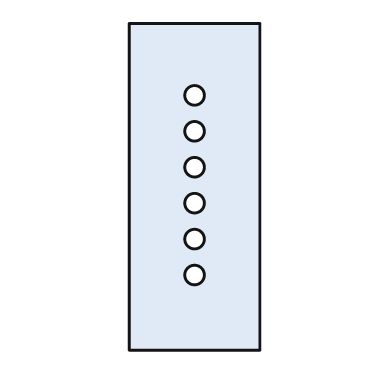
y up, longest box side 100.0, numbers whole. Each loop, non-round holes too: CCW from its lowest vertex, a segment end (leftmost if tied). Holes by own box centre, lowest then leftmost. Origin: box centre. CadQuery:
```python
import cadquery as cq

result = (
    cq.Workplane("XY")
    .moveTo(-20.0, -50.0)
    .lineTo(20.0, -50.0)
    .lineTo(20.0, 50.0)
    .lineTo(-20.0, 50.0)
    .close()
    .moveTo(0.0, -27.0)
    .circle(3.0)
    .moveTo(0.0, -16.0)
    .circle(3.0)
    .moveTo(0.0, -5.0)
    .circle(3.0)
    .moveTo(0.0, 6.0)
    .circle(3.0)
    .moveTo(0.0, 17.0)
    .circle(3.0)
    .moveTo(0.0, 28.0)
    .circle(3.0)
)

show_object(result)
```